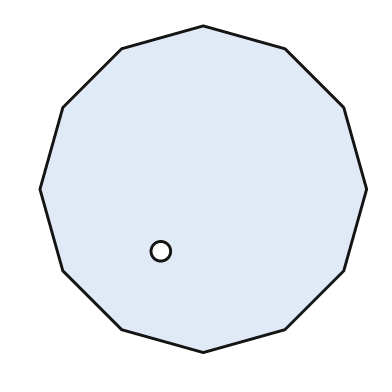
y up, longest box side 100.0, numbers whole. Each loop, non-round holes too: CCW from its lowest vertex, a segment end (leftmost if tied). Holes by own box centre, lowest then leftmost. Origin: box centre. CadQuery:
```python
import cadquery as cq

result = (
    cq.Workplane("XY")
    .moveTo(0.0, -50.0)
    .lineTo(25.0, -43.0)
    .lineTo(43.0, -25.0)
    .lineTo(50.0, 0.0)
    .lineTo(43.0, 25.0)
    .lineTo(25.0, 43.0)
    .lineTo(0.0, 50.0)
    .lineTo(-25.0, 43.0)
    .lineTo(-43.0, 25.0)
    .lineTo(-50.0, 0.0)
    .lineTo(-43.0, -25.0)
    .lineTo(-25.0, -43.0)
    .close()
    .moveTo(-13.0, -19.0)
    .circle(3.0)
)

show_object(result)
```